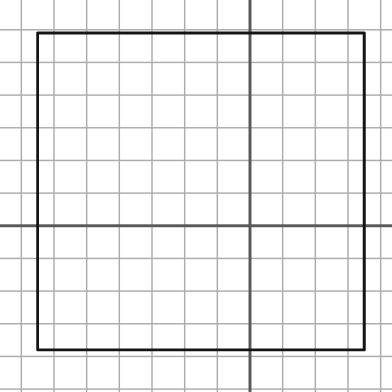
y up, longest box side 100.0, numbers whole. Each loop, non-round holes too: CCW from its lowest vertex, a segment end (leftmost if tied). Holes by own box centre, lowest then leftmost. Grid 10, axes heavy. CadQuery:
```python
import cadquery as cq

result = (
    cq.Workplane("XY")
    .moveTo(-65.0, -38.0)
    .lineTo(35.0, -38.0)
    .lineTo(35.0, 59.0)
    .lineTo(-65.0, 59.0)
    .close()
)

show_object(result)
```